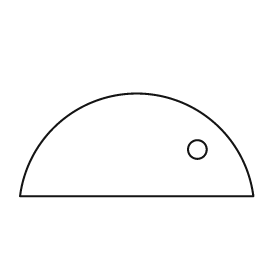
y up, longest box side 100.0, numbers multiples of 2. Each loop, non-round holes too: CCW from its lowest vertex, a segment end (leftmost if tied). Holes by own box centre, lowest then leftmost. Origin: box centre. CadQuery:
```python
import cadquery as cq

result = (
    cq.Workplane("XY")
    .moveTo(-50.0, -22.0)
    .lineTo(50.0, -22.0)
    .threePointArc((0.0, 22.0), (-50.0, -22.0))
    .close()
    .moveTo(26.0, -2.0)
    .circle(4.0)
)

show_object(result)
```